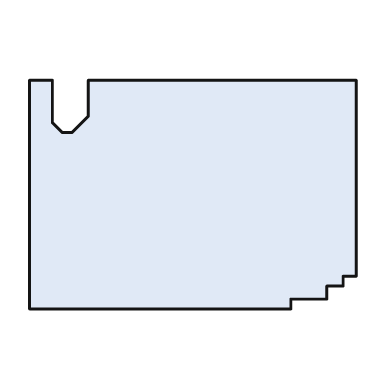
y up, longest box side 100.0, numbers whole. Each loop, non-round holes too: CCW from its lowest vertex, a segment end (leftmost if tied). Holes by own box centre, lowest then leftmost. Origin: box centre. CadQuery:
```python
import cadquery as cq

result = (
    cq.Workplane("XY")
    .moveTo(-50.0, -35.0)
    .lineTo(30.0, -35.0)
    .lineTo(30.0, -32.0)
    .lineTo(41.0, -32.0)
    .lineTo(41.0, -28.0)
    .lineTo(46.0, -28.0)
    .lineTo(46.0, -25.0)
    .lineTo(50.0, -25.0)
    .lineTo(50.0, 35.0)
    .lineTo(-32.0, 35.0)
    .lineTo(-32.0, 24.0)
    .lineTo(-37.0, 19.0)
    .lineTo(-40.0, 19.0)
    .lineTo(-43.0, 22.0)
    .lineTo(-43.0, 35.0)
    .lineTo(-50.0, 35.0)
    .close()
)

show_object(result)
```